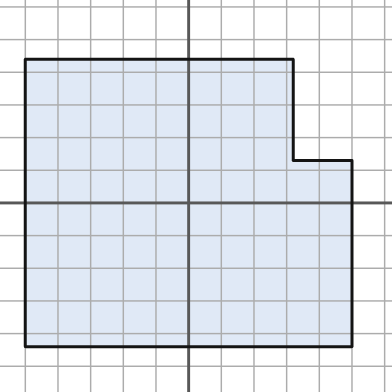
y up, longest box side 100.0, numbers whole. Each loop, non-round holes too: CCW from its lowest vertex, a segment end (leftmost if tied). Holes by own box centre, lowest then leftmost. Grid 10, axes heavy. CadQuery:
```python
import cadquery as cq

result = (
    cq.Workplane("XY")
    .moveTo(-50.0, -44.0)
    .lineTo(50.0, -44.0)
    .lineTo(50.0, 13.0)
    .lineTo(32.0, 13.0)
    .lineTo(32.0, 44.0)
    .lineTo(-50.0, 44.0)
    .close()
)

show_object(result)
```